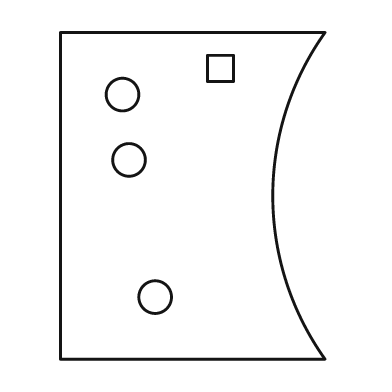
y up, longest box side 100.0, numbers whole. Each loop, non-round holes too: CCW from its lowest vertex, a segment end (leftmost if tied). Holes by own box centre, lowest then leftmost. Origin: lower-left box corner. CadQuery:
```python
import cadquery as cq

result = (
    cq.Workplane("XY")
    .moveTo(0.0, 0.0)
    .lineTo(81.0, 0.0)
    .threePointArc((65.0, 50.0), (81.0, 100.0))
    .lineTo(0.0, 100.0)
    .close()
    .moveTo(29.0, 19.0)
    .circle(5.0)
    .moveTo(21.0, 61.0)
    .circle(5.0)
    .moveTo(19.0, 81.0)
    .circle(5.0)
    .moveTo(45.0, 85.0)
    .lineTo(53.0, 85.0)
    .lineTo(53.0, 93.0)
    .lineTo(45.0, 93.0)
    .close()
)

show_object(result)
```